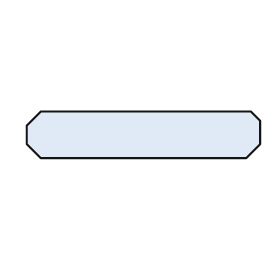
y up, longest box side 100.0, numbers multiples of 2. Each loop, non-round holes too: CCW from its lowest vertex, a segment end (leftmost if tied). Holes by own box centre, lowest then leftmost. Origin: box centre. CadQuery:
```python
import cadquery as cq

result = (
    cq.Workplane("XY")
    .moveTo(-44.0, -10.0)
    .lineTo(44.0, -10.0)
    .lineTo(50.0, -4.0)
    .lineTo(50.0, 6.0)
    .lineTo(46.0, 10.0)
    .lineTo(-44.0, 10.0)
    .lineTo(-50.0, 4.0)
    .lineTo(-50.0, -4.0)
    .close()
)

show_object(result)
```